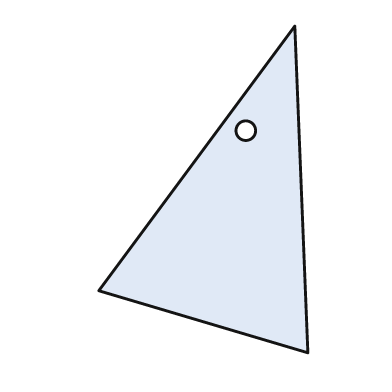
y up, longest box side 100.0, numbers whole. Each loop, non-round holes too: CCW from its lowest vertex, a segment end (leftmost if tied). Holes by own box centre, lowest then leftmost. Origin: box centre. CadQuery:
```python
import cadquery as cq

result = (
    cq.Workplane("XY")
    .moveTo(32.0, -50.0)
    .lineTo(28.0, 50.0)
    .lineTo(-32.0, -31.0)
    .close()
    .moveTo(13.0, 18.0)
    .circle(3.0)
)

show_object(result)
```